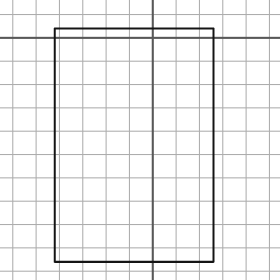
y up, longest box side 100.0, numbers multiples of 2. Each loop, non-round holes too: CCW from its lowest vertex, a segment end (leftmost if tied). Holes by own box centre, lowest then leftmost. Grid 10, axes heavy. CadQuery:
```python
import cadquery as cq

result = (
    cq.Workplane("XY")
    .moveTo(-42.0, -96.0)
    .lineTo(26.0, -96.0)
    .lineTo(26.0, 4.0)
    .lineTo(-42.0, 4.0)
    .close()
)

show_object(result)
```